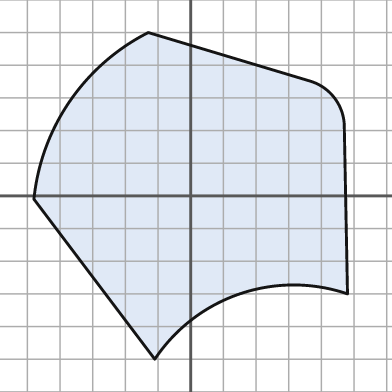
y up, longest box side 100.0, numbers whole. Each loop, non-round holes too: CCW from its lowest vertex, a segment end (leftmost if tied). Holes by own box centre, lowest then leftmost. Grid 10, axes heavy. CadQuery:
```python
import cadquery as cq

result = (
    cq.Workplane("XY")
    .moveTo(-11.0, -50.0)
    .threePointArc((15.0, -30.0), (48.0, -30.0))
    .lineTo(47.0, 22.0)
    .threePointArc((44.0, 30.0), (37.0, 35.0))
    .lineTo(-13.0, 50.0)
    .threePointArc((-37.0, 29.0), (-48.0, -1.0))
    .close()
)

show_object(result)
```